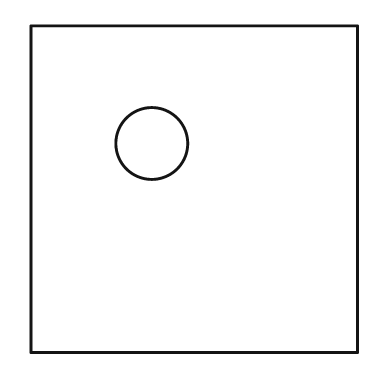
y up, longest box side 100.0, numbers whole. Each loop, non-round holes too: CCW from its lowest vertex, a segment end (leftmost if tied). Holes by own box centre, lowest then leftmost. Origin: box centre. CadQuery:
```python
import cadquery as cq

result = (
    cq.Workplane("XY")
    .moveTo(-50.0, -50.0)
    .lineTo(50.0, -50.0)
    .lineTo(50.0, 50.0)
    .lineTo(-50.0, 50.0)
    .close()
    .moveTo(-13.0, 14.0)
    .circle(11.0)
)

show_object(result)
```